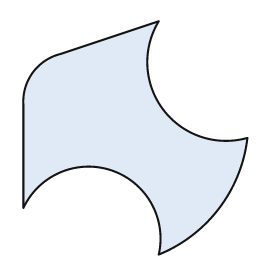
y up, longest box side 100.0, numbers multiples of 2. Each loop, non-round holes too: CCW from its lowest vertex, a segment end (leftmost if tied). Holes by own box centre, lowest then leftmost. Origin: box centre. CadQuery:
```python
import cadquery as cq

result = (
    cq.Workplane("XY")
    .moveTo(10.0, -50.0)
    .threePointArc((36.0, -30.0), (48.0, 0.0))
    .threePointArc((12.0, 12.0), (10.0, 50.0))
    .lineTo(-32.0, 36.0)
    .threePointArc((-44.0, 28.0), (-48.0, 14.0))
    .lineTo(-48.0, -30.0)
    .threePointArc((-10.0, -14.0), (10.0, -50.0))
    .close()
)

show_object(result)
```